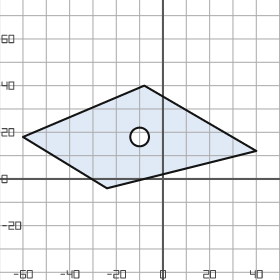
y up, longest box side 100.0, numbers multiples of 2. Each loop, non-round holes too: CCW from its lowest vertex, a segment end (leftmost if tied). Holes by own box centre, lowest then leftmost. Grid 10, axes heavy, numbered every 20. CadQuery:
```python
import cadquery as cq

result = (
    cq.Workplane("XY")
    .moveTo(-24.0, -4.0)
    .lineTo(40.0, 12.0)
    .lineTo(-8.0, 40.0)
    .lineTo(-60.0, 18.0)
    .close()
    .moveTo(-10.0, 18.0)
    .circle(4.0)
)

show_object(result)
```